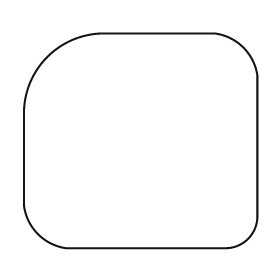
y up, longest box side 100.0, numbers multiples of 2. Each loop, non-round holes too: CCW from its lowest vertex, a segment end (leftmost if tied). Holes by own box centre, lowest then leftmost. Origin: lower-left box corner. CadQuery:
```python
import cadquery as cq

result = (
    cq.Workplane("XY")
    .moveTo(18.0, 0.0)
    .lineTo(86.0, 0.0)
    .threePointArc((96.0, 4.0), (100.0, 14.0))
    .lineTo(100.0, 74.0)
    .threePointArc((94.0, 86.0), (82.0, 92.0))
    .lineTo(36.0, 92.0)
    .threePointArc((10.0, 82.0), (0.0, 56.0))
    .lineTo(0.0, 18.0)
    .threePointArc((6.0, 6.0), (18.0, 0.0))
    .close()
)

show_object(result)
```